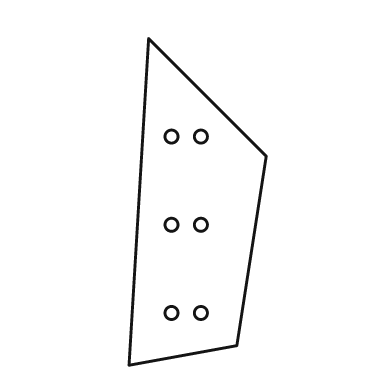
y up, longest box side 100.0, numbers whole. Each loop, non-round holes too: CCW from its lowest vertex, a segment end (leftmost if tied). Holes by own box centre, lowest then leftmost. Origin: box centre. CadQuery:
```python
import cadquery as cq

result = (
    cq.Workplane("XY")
    .moveTo(-21.0, -50.0)
    .lineTo(12.0, -44.0)
    .lineTo(21.0, 14.0)
    .lineTo(-15.0, 50.0)
    .close()
    .moveTo(-8.0, -34.0)
    .circle(2.0)
    .moveTo(1.0, -34.0)
    .circle(2.0)
    .moveTo(-8.0, -7.0)
    .circle(2.0)
    .moveTo(1.0, -7.0)
    .circle(2.0)
    .moveTo(-8.0, 20.0)
    .circle(2.0)
    .moveTo(1.0, 20.0)
    .circle(2.0)
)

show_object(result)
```